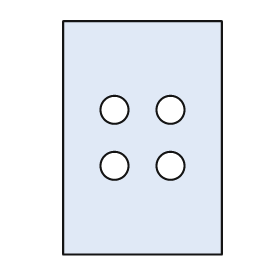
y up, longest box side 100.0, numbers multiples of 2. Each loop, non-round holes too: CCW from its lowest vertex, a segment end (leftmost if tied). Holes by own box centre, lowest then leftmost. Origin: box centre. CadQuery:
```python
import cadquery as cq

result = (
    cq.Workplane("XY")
    .moveTo(-34.0, -50.0)
    .lineTo(34.0, -50.0)
    .lineTo(34.0, 50.0)
    .lineTo(-34.0, 50.0)
    .close()
    .moveTo(-12.0, -12.0)
    .circle(6.0)
    .moveTo(12.0, -12.0)
    .circle(6.0)
    .moveTo(-12.0, 12.0)
    .circle(6.0)
    .moveTo(12.0, 12.0)
    .circle(6.0)
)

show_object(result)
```